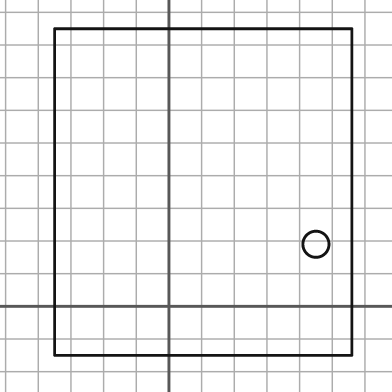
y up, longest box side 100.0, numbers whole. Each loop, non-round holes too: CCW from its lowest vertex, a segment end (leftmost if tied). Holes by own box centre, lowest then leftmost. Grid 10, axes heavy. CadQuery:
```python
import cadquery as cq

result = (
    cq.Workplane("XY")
    .moveTo(-35.0, -15.0)
    .lineTo(56.0, -15.0)
    .lineTo(56.0, 85.0)
    .lineTo(-35.0, 85.0)
    .close()
    .moveTo(45.0, 19.0)
    .circle(4.0)
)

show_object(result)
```